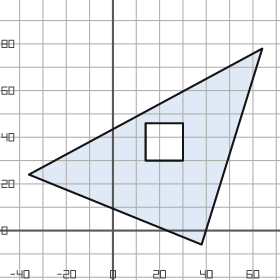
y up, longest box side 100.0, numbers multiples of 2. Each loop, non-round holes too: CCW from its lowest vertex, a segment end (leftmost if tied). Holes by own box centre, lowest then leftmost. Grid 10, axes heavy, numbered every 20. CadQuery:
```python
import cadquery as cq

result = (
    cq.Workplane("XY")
    .moveTo(38.0, -6.0)
    .lineTo(64.0, 78.0)
    .lineTo(-36.0, 24.0)
    .close()
    .moveTo(14.0, 30.0)
    .lineTo(30.0, 30.0)
    .lineTo(30.0, 46.0)
    .lineTo(14.0, 46.0)
    .close()
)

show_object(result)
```